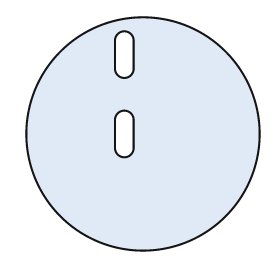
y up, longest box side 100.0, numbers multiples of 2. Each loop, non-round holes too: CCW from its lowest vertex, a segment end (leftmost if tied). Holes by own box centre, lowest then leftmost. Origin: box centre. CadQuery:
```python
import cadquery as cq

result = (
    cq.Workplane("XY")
    .moveTo(0.0, 0.0)
    .circle(50.0)
    .moveTo(-12.0, -6.0)
    .threePointArc((-8.0, -10.0), (-4.0, -6.0))
    .lineTo(-4.0, 6.0)
    .threePointArc((-8.0, 10.0), (-12.0, 6.0))
    .close()
    .moveTo(-12.0, 28.0)
    .threePointArc((-8.0, 24.0), (-4.0, 28.0))
    .lineTo(-4.0, 40.0)
    .threePointArc((-8.0, 44.0), (-12.0, 40.0))
    .close()
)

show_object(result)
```